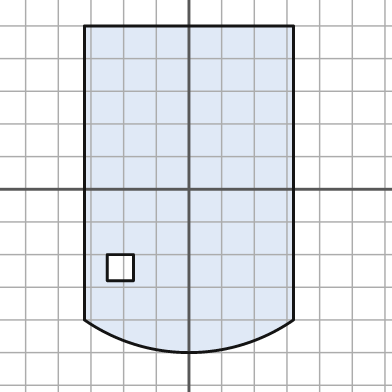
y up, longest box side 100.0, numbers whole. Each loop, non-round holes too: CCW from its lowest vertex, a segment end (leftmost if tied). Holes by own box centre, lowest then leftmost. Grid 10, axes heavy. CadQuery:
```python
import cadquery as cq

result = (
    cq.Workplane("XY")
    .moveTo(-32.0, -40.0)
    .threePointArc((0.0, -50.0), (32.0, -40.0))
    .lineTo(32.0, 50.0)
    .lineTo(-32.0, 50.0)
    .close()
    .moveTo(-25.0, -28.0)
    .lineTo(-17.0, -28.0)
    .lineTo(-17.0, -20.0)
    .lineTo(-25.0, -20.0)
    .close()
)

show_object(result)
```